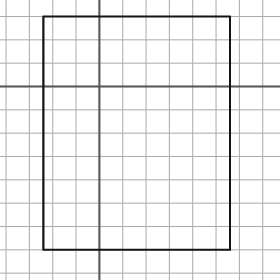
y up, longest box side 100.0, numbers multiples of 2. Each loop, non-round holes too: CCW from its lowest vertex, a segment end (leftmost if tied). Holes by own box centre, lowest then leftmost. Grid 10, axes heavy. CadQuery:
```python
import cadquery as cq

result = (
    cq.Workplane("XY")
    .moveTo(-24.0, -70.0)
    .lineTo(56.0, -70.0)
    .lineTo(56.0, 30.0)
    .lineTo(-24.0, 30.0)
    .close()
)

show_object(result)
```